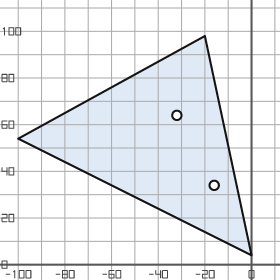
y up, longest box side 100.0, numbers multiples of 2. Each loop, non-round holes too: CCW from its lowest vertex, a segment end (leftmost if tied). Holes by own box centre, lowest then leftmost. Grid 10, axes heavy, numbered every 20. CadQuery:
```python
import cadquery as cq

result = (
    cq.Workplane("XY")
    .moveTo(0.0, 4.0)
    .lineTo(-20.0, 98.0)
    .lineTo(-100.0, 54.0)
    .close()
    .moveTo(-16.0, 34.0)
    .circle(2.0)
    .moveTo(-32.0, 64.0)
    .circle(2.0)
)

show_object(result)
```